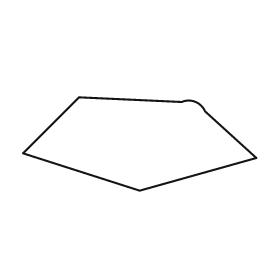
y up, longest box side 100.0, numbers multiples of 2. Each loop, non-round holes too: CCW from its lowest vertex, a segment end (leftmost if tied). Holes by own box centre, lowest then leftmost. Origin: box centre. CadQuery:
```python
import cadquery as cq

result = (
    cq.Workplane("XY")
    .moveTo(0.0, -20.0)
    .lineTo(50.0, -6.0)
    .lineTo(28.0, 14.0)
    .threePointArc((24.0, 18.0), (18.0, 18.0))
    .lineTo(-26.0, 20.0)
    .lineTo(-50.0, -4.0)
    .close()
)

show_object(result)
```